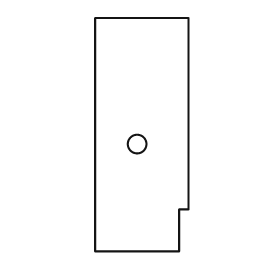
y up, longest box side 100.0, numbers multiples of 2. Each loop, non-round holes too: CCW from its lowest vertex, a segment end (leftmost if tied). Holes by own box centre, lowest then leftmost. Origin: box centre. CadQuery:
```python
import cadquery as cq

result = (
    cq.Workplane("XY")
    .moveTo(-20.0, -50.0)
    .lineTo(16.0, -50.0)
    .lineTo(16.0, -32.0)
    .lineTo(20.0, -32.0)
    .lineTo(20.0, 50.0)
    .lineTo(-20.0, 50.0)
    .close()
    .moveTo(-2.0, -4.0)
    .circle(4.0)
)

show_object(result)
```